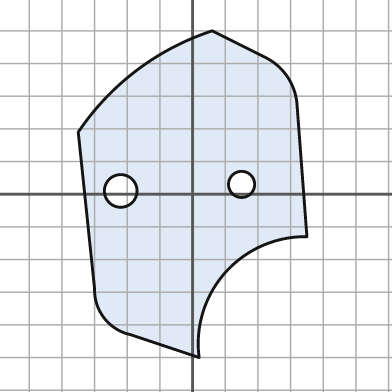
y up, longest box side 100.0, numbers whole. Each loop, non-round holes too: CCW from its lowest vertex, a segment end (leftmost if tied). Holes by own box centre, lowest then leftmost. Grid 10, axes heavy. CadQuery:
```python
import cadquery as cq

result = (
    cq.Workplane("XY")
    .moveTo(2.0, -50.0)
    .threePointArc((10.0, -24.0), (35.0, -13.0))
    .lineTo(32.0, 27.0)
    .threePointArc((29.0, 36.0), (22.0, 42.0))
    .lineTo(6.0, 50.0)
    .threePointArc((-17.0, 38.0), (-35.0, 19.0))
    .lineTo(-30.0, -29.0)
    .threePointArc((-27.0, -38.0), (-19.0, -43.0))
    .close()
    .moveTo(-22.0, 1.0)
    .circle(5.0)
    .moveTo(15.0, 3.0)
    .circle(4.0)
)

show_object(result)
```